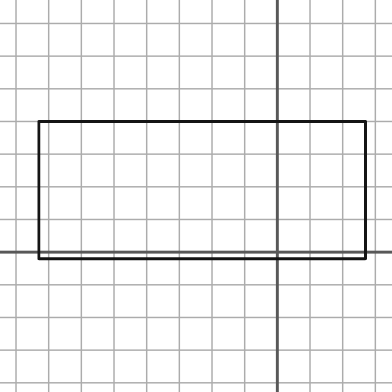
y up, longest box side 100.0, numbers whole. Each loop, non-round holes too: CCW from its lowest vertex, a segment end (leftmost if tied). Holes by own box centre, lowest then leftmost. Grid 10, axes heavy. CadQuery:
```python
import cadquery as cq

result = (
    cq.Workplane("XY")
    .moveTo(-73.0, -2.0)
    .lineTo(27.0, -2.0)
    .lineTo(27.0, 40.0)
    .lineTo(-73.0, 40.0)
    .close()
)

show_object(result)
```